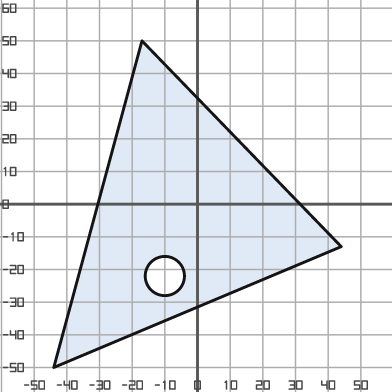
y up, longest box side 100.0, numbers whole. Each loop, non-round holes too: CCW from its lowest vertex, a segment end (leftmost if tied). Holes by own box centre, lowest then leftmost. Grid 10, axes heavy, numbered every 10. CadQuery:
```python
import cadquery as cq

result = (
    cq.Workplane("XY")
    .moveTo(-44.0, -50.0)
    .lineTo(44.0, -13.0)
    .lineTo(-17.0, 50.0)
    .close()
    .moveTo(-10.0, -22.0)
    .circle(6.0)
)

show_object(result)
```